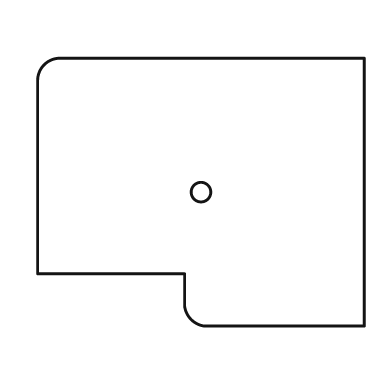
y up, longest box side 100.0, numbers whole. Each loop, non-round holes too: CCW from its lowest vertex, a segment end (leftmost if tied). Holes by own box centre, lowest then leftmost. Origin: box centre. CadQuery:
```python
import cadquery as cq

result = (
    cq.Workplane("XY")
    .moveTo(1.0, -41.0)
    .lineTo(50.0, -41.0)
    .lineTo(50.0, 41.0)
    .lineTo(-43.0, 41.0)
    .threePointArc((-48.0, 39.0), (-50.0, 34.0))
    .lineTo(-50.0, -25.0)
    .lineTo(-5.0, -25.0)
    .lineTo(-5.0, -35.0)
    .threePointArc((-3.0, -39.0), (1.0, -41.0))
    .close()
    .moveTo(0.0, 0.0)
    .circle(3.0)
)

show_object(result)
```